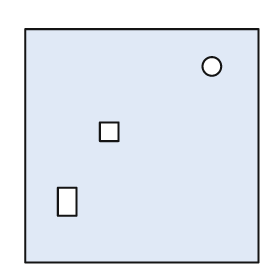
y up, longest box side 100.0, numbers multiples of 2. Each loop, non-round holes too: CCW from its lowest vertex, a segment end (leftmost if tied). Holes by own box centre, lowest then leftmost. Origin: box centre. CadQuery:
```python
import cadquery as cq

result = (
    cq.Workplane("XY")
    .moveTo(-50.0, -50.0)
    .lineTo(50.0, -50.0)
    .lineTo(50.0, 50.0)
    .lineTo(-50.0, 50.0)
    .close()
    .moveTo(-36.0, -30.0)
    .lineTo(-28.0, -30.0)
    .lineTo(-28.0, -18.0)
    .lineTo(-36.0, -18.0)
    .close()
    .moveTo(-18.0, 2.0)
    .lineTo(-10.0, 2.0)
    .lineTo(-10.0, 10.0)
    .lineTo(-18.0, 10.0)
    .close()
    .moveTo(30.0, 34.0)
    .circle(4.0)
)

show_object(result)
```